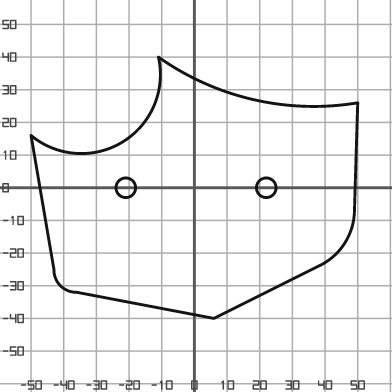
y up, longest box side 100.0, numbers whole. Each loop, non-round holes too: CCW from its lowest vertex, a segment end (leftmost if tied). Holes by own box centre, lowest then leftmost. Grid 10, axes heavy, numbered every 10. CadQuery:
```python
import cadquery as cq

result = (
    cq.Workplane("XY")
    .moveTo(6.0, -40.0)
    .lineTo(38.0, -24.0)
    .threePointArc((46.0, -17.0), (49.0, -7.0))
    .lineTo(50.0, 26.0)
    .threePointArc((18.0, 27.0), (-11.0, 40.0))
    .threePointArc((-22.0, 14.0), (-50.0, 16.0))
    .lineTo(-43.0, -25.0)
    .threePointArc((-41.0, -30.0), (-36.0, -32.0))
    .close()
    .moveTo(-21.0, 0.0)
    .circle(3.0)
    .moveTo(22.0, 0.0)
    .circle(3.0)
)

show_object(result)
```